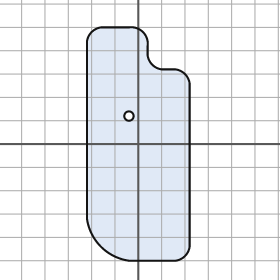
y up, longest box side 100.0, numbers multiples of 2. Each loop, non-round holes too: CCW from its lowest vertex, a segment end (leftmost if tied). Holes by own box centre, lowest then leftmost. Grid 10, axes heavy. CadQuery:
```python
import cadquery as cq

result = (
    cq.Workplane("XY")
    .moveTo(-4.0, -50.0)
    .lineTo(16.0, -50.0)
    .threePointArc((20.0, -48.0), (22.0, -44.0))
    .lineTo(22.0, 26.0)
    .threePointArc((20.0, 30.0), (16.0, 32.0))
    .lineTo(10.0, 32.0)
    .threePointArc((6.0, 34.0), (4.0, 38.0))
    .lineTo(4.0, 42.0)
    .threePointArc((2.0, 48.0), (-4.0, 50.0))
    .lineTo(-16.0, 50.0)
    .threePointArc((-20.0, 48.0), (-22.0, 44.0))
    .lineTo(-22.0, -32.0)
    .threePointArc((-16.0, -44.0), (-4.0, -50.0))
    .close()
    .moveTo(-4.0, 12.0)
    .circle(2.0)
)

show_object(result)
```